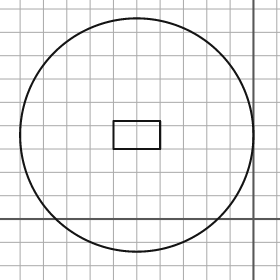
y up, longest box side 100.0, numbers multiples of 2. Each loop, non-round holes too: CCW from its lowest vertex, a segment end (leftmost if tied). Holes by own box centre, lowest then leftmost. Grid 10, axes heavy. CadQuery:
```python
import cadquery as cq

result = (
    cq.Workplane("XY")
    .moveTo(-50.0, 36.0)
    .circle(50.0)
    .moveTo(-60.0, 30.0)
    .lineTo(-40.0, 30.0)
    .lineTo(-40.0, 42.0)
    .lineTo(-60.0, 42.0)
    .close()
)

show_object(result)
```